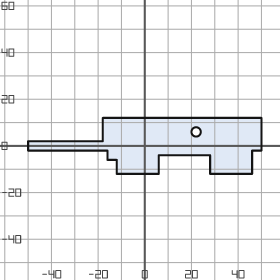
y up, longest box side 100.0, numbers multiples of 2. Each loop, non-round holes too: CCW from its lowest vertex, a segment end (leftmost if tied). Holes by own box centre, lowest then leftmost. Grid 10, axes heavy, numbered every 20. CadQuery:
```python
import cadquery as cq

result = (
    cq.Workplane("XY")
    .moveTo(-12.0, -12.0)
    .lineTo(6.0, -12.0)
    .lineTo(6.0, -4.0)
    .lineTo(28.0, -4.0)
    .lineTo(28.0, -12.0)
    .lineTo(46.0, -12.0)
    .lineTo(46.0, -2.0)
    .lineTo(50.0, -2.0)
    .lineTo(50.0, 12.0)
    .lineTo(-18.0, 12.0)
    .lineTo(-18.0, 2.0)
    .lineTo(-50.0, 2.0)
    .lineTo(-50.0, -2.0)
    .lineTo(-16.0, -2.0)
    .lineTo(-16.0, -6.0)
    .lineTo(-12.0, -6.0)
    .close()
    .moveTo(22.0, 6.0)
    .circle(2.0)
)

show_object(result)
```